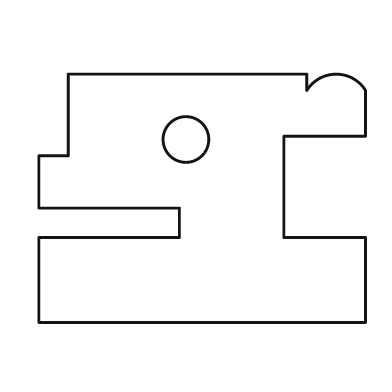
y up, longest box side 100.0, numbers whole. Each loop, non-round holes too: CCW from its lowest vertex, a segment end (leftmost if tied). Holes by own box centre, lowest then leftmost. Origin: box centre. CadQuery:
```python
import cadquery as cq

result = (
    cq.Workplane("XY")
    .moveTo(-50.0, -38.0)
    .lineTo(50.0, -38.0)
    .lineTo(50.0, -12.0)
    .lineTo(25.0, -12.0)
    .lineTo(25.0, 19.0)
    .lineTo(50.0, 19.0)
    .lineTo(50.0, 33.0)
    .threePointArc((41.0, 38.0), (32.0, 33.0))
    .lineTo(32.0, 38.0)
    .lineTo(-41.0, 38.0)
    .lineTo(-41.0, 13.0)
    .lineTo(-50.0, 13.0)
    .lineTo(-50.0, -3.0)
    .lineTo(-7.0, -3.0)
    .lineTo(-7.0, -12.0)
    .lineTo(-50.0, -12.0)
    .close()
    .moveTo(-5.0, 18.0)
    .circle(7.0)
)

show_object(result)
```